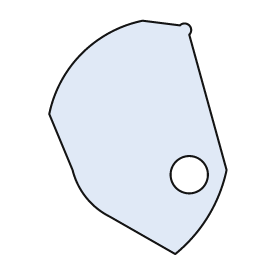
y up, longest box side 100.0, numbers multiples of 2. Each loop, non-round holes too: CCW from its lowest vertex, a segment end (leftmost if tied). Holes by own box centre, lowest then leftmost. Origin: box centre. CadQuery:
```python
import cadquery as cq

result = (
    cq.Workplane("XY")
    .moveTo(16.0, -50.0)
    .threePointArc((30.0, -34.0), (38.0, -14.0))
    .lineTo(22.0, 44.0)
    .threePointArc((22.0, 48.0), (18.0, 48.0))
    .lineTo(2.0, 50.0)
    .threePointArc((-24.0, 36.0), (-38.0, 10.0))
    .lineTo(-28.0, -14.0)
    .threePointArc((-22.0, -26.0), (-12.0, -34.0))
    .close()
    .moveTo(22.0, -16.0)
    .circle(8.0)
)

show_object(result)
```